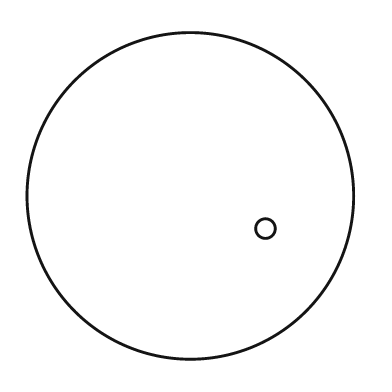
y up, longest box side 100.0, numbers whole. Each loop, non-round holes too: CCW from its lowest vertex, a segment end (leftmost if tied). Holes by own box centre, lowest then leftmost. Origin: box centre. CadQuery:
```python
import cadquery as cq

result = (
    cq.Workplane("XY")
    .moveTo(0.0, 0.0)
    .circle(50.0)
    .moveTo(23.0, -10.0)
    .circle(3.0)
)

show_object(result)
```